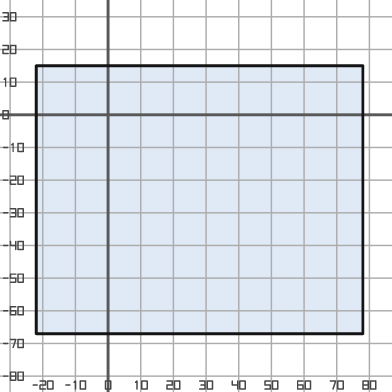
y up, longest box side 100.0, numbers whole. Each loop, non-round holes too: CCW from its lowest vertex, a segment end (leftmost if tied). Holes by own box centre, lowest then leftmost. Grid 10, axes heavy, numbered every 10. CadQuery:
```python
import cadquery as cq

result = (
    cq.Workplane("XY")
    .moveTo(-22.0, -67.0)
    .lineTo(78.0, -67.0)
    .lineTo(78.0, 15.0)
    .lineTo(-22.0, 15.0)
    .close()
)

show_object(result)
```